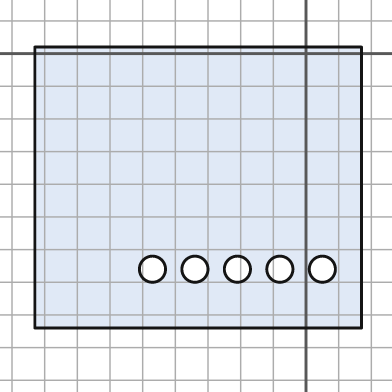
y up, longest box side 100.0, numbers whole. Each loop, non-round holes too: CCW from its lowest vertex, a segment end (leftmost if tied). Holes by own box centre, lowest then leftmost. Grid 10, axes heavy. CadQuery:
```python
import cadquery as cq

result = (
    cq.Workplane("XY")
    .moveTo(-83.0, -84.0)
    .lineTo(17.0, -84.0)
    .lineTo(17.0, 2.0)
    .lineTo(-83.0, 2.0)
    .close()
    .moveTo(-47.0, -66.0)
    .circle(4.0)
    .moveTo(-34.0, -66.0)
    .circle(4.0)
    .moveTo(-21.0, -66.0)
    .circle(4.0)
    .moveTo(-8.0, -66.0)
    .circle(4.0)
    .moveTo(5.0, -66.0)
    .circle(4.0)
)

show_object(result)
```